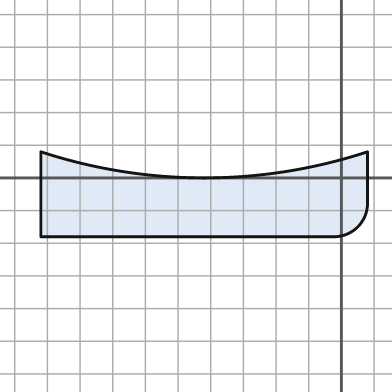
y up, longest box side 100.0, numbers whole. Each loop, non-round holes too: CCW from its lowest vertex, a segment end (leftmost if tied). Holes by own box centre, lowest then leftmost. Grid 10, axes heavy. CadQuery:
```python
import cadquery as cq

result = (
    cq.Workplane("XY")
    .moveTo(-92.0, -18.0)
    .lineTo(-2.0, -18.0)
    .threePointArc((5.0, -15.0), (8.0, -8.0))
    .lineTo(8.0, 8.0)
    .threePointArc((-42.0, 0.0), (-92.0, 8.0))
    .close()
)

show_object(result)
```